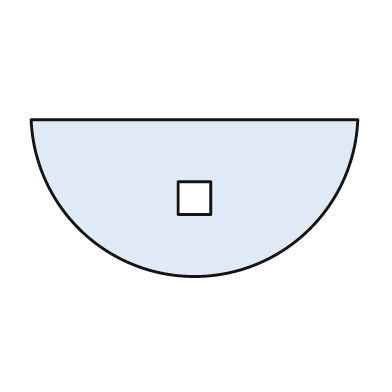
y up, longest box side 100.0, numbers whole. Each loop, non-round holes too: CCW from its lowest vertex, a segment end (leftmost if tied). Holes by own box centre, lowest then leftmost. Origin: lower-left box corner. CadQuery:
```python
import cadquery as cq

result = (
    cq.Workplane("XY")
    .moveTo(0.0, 48.0)
    .threePointArc((50.0, 0.0), (100.0, 48.0))
    .close()
    .moveTo(45.0, 19.0)
    .lineTo(55.0, 19.0)
    .lineTo(55.0, 29.0)
    .lineTo(45.0, 29.0)
    .close()
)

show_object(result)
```